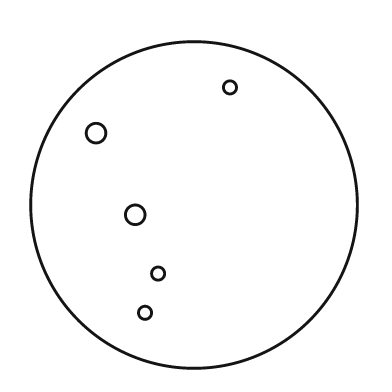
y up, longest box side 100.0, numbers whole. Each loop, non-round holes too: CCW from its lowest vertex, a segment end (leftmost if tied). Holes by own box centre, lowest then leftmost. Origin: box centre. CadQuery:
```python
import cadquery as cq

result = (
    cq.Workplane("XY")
    .moveTo(0.0, 0.0)
    .circle(50.0)
    .moveTo(-15.0, -33.0)
    .circle(2.0)
    .moveTo(-11.0, -21.0)
    .circle(2.0)
    .moveTo(-18.0, -3.0)
    .circle(3.0)
    .moveTo(-30.0, 22.0)
    .circle(3.0)
    .moveTo(11.0, 36.0)
    .circle(2.0)
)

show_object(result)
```